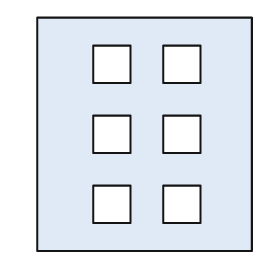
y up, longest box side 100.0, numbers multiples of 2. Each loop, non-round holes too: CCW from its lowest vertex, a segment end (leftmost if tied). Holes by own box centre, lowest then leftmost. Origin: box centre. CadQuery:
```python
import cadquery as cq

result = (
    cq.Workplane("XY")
    .moveTo(-46.0, -50.0)
    .lineTo(46.0, -50.0)
    .lineTo(46.0, 50.0)
    .lineTo(-46.0, 50.0)
    .close()
    .moveTo(-22.0, -38.0)
    .lineTo(-6.0, -38.0)
    .lineTo(-6.0, -22.0)
    .lineTo(-22.0, -22.0)
    .close()
    .moveTo(8.0, -38.0)
    .lineTo(24.0, -38.0)
    .lineTo(24.0, -22.0)
    .lineTo(8.0, -22.0)
    .close()
    .moveTo(-22.0, -8.0)
    .lineTo(-6.0, -8.0)
    .lineTo(-6.0, 8.0)
    .lineTo(-22.0, 8.0)
    .close()
    .moveTo(8.0, -8.0)
    .lineTo(24.0, -8.0)
    .lineTo(24.0, 8.0)
    .lineTo(8.0, 8.0)
    .close()
    .moveTo(-22.0, 22.0)
    .lineTo(-6.0, 22.0)
    .lineTo(-6.0, 38.0)
    .lineTo(-22.0, 38.0)
    .close()
    .moveTo(8.0, 22.0)
    .lineTo(24.0, 22.0)
    .lineTo(24.0, 38.0)
    .lineTo(8.0, 38.0)
    .close()
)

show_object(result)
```